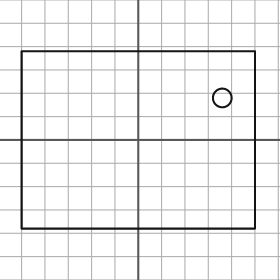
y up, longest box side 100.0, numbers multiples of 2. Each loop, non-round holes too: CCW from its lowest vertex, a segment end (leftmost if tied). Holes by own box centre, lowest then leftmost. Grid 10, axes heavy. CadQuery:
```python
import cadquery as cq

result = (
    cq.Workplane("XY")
    .moveTo(-50.0, -38.0)
    .lineTo(50.0, -38.0)
    .lineTo(50.0, 38.0)
    .lineTo(-50.0, 38.0)
    .close()
    .moveTo(36.0, 18.0)
    .circle(4.0)
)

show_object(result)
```